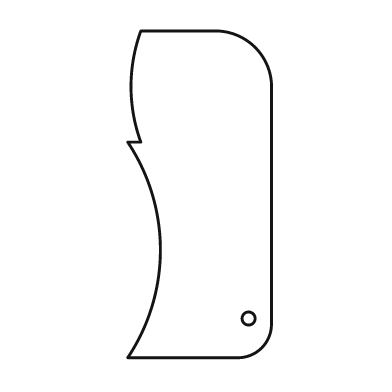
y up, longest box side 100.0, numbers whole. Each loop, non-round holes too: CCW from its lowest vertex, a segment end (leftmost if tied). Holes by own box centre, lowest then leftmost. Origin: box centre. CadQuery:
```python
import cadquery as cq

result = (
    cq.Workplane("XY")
    .moveTo(-22.0, -50.0)
    .lineTo(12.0, -50.0)
    .threePointArc((19.0, -47.0), (22.0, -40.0))
    .lineTo(22.0, 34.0)
    .threePointArc((17.0, 45.0), (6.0, 50.0))
    .lineTo(-18.0, 50.0)
    .threePointArc((-21.0, 33.0), (-18.0, 16.0))
    .lineTo(-22.0, 16.0)
    .threePointArc((-12.0, -17.0), (-22.0, -50.0))
    .close()
    .moveTo(15.0, -38.0)
    .circle(2.0)
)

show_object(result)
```